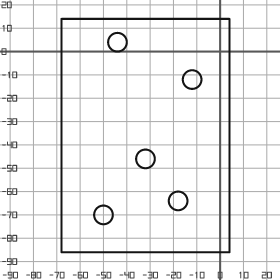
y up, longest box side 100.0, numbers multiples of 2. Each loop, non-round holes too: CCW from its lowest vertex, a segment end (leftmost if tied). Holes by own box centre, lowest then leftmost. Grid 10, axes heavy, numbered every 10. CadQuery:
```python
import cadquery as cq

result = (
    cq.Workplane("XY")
    .moveTo(-68.0, -86.0)
    .lineTo(4.0, -86.0)
    .lineTo(4.0, 14.0)
    .lineTo(-68.0, 14.0)
    .close()
    .moveTo(-50.0, -70.0)
    .circle(4.0)
    .moveTo(-18.0, -64.0)
    .circle(4.0)
    .moveTo(-32.0, -46.0)
    .circle(4.0)
    .moveTo(-12.0, -12.0)
    .circle(4.0)
    .moveTo(-44.0, 4.0)
    .circle(4.0)
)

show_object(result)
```